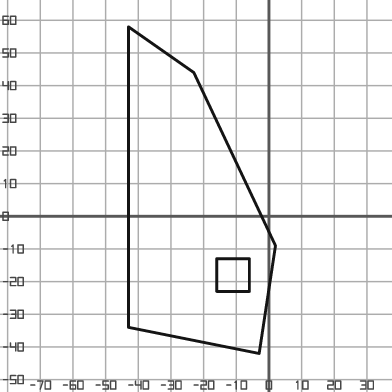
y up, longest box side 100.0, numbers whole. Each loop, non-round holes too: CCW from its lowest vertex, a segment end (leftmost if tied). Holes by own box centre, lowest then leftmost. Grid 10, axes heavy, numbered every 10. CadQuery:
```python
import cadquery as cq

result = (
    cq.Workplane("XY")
    .moveTo(-3.0, -42.0)
    .lineTo(2.0, -9.0)
    .lineTo(-23.0, 44.0)
    .lineTo(-43.0, 58.0)
    .lineTo(-43.0, -34.0)
    .close()
    .moveTo(-16.0, -23.0)
    .lineTo(-6.0, -23.0)
    .lineTo(-6.0, -13.0)
    .lineTo(-16.0, -13.0)
    .close()
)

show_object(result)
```